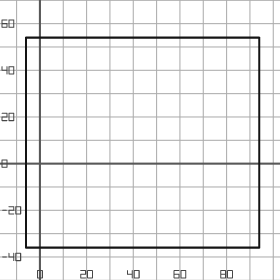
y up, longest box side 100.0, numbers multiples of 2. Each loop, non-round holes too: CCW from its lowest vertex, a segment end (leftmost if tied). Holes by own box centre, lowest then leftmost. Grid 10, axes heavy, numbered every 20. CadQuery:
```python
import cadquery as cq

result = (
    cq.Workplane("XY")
    .moveTo(-6.0, -36.0)
    .lineTo(94.0, -36.0)
    .lineTo(94.0, 54.0)
    .lineTo(-6.0, 54.0)
    .close()
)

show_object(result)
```